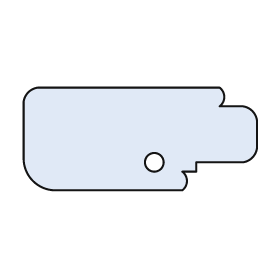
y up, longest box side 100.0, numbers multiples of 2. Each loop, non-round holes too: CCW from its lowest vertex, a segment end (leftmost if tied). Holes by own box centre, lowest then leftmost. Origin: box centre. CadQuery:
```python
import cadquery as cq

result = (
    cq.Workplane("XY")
    .moveTo(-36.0, -22.0)
    .lineTo(18.0, -22.0)
    .threePointArc((20.0, -18.0), (18.0, -14.0))
    .lineTo(24.0, -14.0)
    .lineTo(24.0, -10.0)
    .lineTo(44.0, -10.0)
    .threePointArc((48.0, -8.0), (50.0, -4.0))
    .lineTo(50.0, 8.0)
    .threePointArc((48.0, 12.0), (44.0, 14.0))
    .lineTo(34.0, 14.0)
    .threePointArc((36.0, 18.0), (34.0, 22.0))
    .lineTo(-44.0, 22.0)
    .threePointArc((-48.0, 20.0), (-50.0, 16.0))
    .lineTo(-50.0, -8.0)
    .threePointArc((-46.0, -18.0), (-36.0, -22.0))
    .close()
    .moveTo(6.0, -10.0)
    .circle(4.0)
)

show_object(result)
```